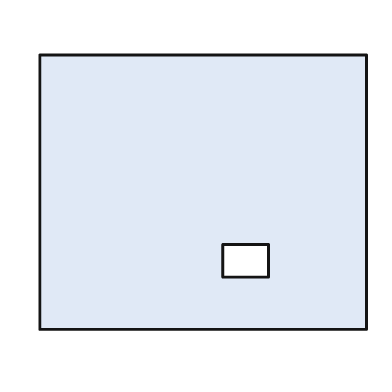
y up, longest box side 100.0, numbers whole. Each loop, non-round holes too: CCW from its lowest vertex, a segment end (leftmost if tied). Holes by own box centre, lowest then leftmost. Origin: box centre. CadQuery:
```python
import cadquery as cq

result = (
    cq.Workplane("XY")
    .moveTo(-50.0, -42.0)
    .lineTo(50.0, -42.0)
    .lineTo(50.0, 42.0)
    .lineTo(-50.0, 42.0)
    .close()
    .moveTo(6.0, -26.0)
    .lineTo(20.0, -26.0)
    .lineTo(20.0, -16.0)
    .lineTo(6.0, -16.0)
    .close()
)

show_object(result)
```